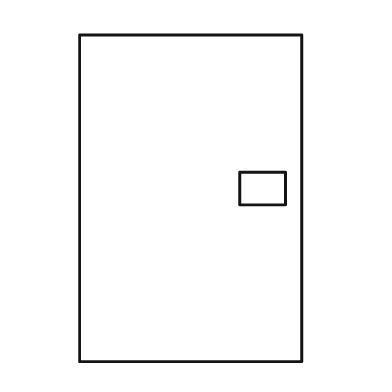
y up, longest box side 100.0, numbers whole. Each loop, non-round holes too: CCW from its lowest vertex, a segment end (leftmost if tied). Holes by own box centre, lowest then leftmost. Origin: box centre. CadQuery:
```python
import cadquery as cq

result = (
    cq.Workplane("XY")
    .moveTo(-34.0, -50.0)
    .lineTo(34.0, -50.0)
    .lineTo(34.0, 50.0)
    .lineTo(-34.0, 50.0)
    .close()
    .moveTo(15.0, -2.0)
    .lineTo(29.0, -2.0)
    .lineTo(29.0, 8.0)
    .lineTo(15.0, 8.0)
    .close()
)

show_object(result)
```